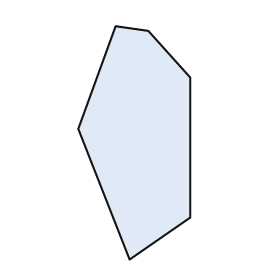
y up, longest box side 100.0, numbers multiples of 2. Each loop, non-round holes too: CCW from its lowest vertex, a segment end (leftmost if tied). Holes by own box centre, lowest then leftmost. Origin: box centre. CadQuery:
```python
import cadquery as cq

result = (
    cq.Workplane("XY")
    .moveTo(-2.0, -50.0)
    .lineTo(24.0, -32.0)
    .lineTo(24.0, 28.0)
    .lineTo(6.0, 48.0)
    .lineTo(-8.0, 50.0)
    .lineTo(-24.0, 6.0)
    .close()
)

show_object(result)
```